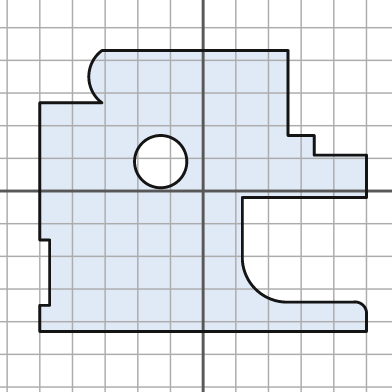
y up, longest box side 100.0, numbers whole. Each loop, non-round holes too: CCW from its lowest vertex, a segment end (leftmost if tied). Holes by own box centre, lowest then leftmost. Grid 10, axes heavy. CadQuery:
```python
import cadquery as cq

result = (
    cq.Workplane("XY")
    .moveTo(-50.0, -43.0)
    .lineTo(50.0, -43.0)
    .lineTo(50.0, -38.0)
    .threePointArc((49.0, -35.0), (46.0, -34.0))
    .lineTo(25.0, -34.0)
    .threePointArc((16.0, -30.0), (12.0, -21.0))
    .lineTo(12.0, -2.0)
    .lineTo(50.0, -2.0)
    .lineTo(50.0, 11.0)
    .lineTo(34.0, 11.0)
    .lineTo(34.0, 17.0)
    .lineTo(26.0, 17.0)
    .lineTo(26.0, 43.0)
    .lineTo(-31.0, 43.0)
    .threePointArc((-35.0, 35.0), (-31.0, 27.0))
    .lineTo(-50.0, 27.0)
    .lineTo(-50.0, -15.0)
    .lineTo(-47.0, -15.0)
    .lineTo(-47.0, -35.0)
    .lineTo(-50.0, -35.0)
    .close()
    .moveTo(-13.0, 9.0)
    .circle(8.0)
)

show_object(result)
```